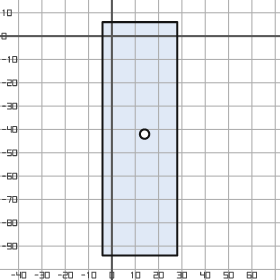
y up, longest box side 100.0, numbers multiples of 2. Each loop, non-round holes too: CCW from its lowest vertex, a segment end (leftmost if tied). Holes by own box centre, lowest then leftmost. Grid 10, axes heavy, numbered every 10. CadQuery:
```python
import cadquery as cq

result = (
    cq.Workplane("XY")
    .moveTo(-4.0, -94.0)
    .lineTo(28.0, -94.0)
    .lineTo(28.0, 6.0)
    .lineTo(-4.0, 6.0)
    .close()
    .moveTo(14.0, -42.0)
    .circle(2.0)
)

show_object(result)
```